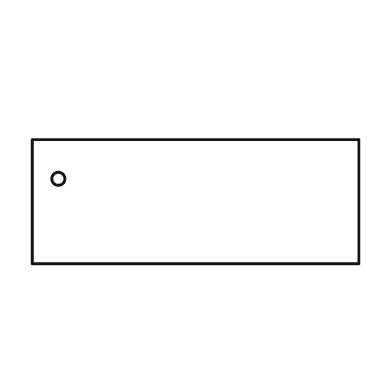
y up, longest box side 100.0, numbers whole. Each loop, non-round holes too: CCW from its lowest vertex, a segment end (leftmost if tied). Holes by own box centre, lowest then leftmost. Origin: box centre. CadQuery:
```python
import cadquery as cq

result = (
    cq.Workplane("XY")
    .moveTo(-50.0, -19.0)
    .lineTo(50.0, -19.0)
    .lineTo(50.0, 19.0)
    .lineTo(-50.0, 19.0)
    .close()
    .moveTo(-42.0, 7.0)
    .circle(2.0)
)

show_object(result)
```